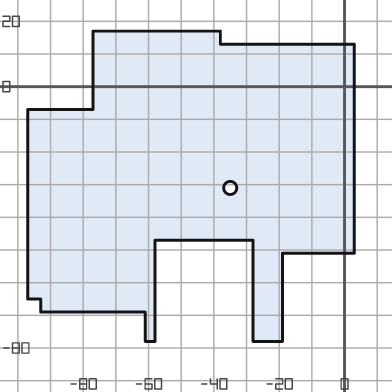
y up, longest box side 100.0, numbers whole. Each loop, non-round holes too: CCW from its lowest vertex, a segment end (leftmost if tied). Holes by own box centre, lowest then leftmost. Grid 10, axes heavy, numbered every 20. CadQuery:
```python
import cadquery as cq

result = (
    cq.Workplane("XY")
    .moveTo(-61.0, -78.0)
    .lineTo(-58.0, -78.0)
    .lineTo(-58.0, -47.0)
    .lineTo(-28.0, -47.0)
    .lineTo(-28.0, -78.0)
    .lineTo(-19.0, -78.0)
    .lineTo(-19.0, -51.0)
    .lineTo(3.0, -51.0)
    .lineTo(3.0, 13.0)
    .lineTo(-38.0, 13.0)
    .lineTo(-38.0, 17.0)
    .lineTo(-77.0, 17.0)
    .lineTo(-77.0, -7.0)
    .lineTo(-97.0, -7.0)
    .lineTo(-97.0, -65.0)
    .lineTo(-93.0, -65.0)
    .lineTo(-93.0, -69.0)
    .lineTo(-61.0, -69.0)
    .close()
    .moveTo(-35.0, -31.0)
    .circle(2.0)
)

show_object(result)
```